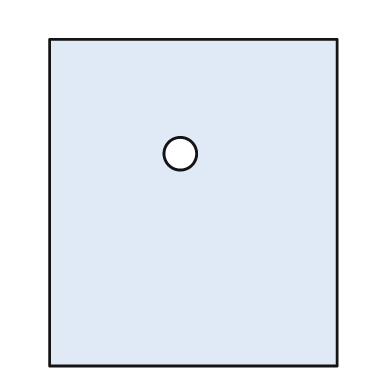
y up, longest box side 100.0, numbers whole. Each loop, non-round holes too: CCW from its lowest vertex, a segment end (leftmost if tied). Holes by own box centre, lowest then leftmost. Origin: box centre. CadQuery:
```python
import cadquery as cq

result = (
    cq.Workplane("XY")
    .moveTo(-44.0, -50.0)
    .lineTo(44.0, -50.0)
    .lineTo(44.0, 50.0)
    .lineTo(-44.0, 50.0)
    .close()
    .moveTo(-4.0, 15.0)
    .circle(5.0)
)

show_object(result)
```